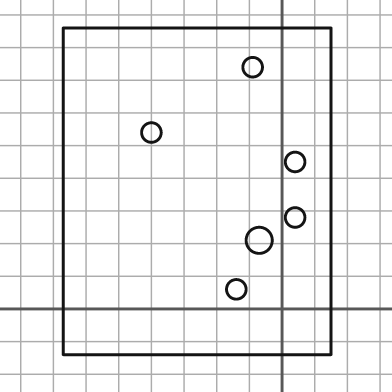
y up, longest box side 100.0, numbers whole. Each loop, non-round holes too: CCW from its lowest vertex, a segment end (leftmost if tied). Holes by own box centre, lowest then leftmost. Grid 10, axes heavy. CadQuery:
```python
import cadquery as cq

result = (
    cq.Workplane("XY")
    .moveTo(-67.0, -14.0)
    .lineTo(15.0, -14.0)
    .lineTo(15.0, 86.0)
    .lineTo(-67.0, 86.0)
    .close()
    .moveTo(-14.0, 6.0)
    .circle(3.0)
    .moveTo(-7.0, 21.0)
    .circle(4.0)
    .moveTo(4.0, 28.0)
    .circle(3.0)
    .moveTo(4.0, 45.0)
    .circle(3.0)
    .moveTo(-40.0, 54.0)
    .circle(3.0)
    .moveTo(-9.0, 74.0)
    .circle(3.0)
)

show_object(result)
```